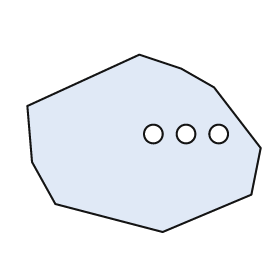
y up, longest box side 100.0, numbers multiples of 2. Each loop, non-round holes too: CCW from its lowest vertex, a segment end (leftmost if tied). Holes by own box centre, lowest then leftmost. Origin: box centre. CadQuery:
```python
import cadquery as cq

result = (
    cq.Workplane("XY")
    .moveTo(8.0, -38.0)
    .lineTo(46.0, -22.0)
    .lineTo(50.0, -2.0)
    .lineTo(30.0, 24.0)
    .lineTo(16.0, 32.0)
    .lineTo(-2.0, 38.0)
    .lineTo(-50.0, 16.0)
    .lineTo(-48.0, -8.0)
    .lineTo(-38.0, -26.0)
    .close()
    .moveTo(4.0, 4.0)
    .circle(4.0)
    .moveTo(18.0, 4.0)
    .circle(4.0)
    .moveTo(32.0, 4.0)
    .circle(4.0)
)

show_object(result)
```